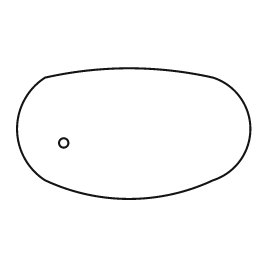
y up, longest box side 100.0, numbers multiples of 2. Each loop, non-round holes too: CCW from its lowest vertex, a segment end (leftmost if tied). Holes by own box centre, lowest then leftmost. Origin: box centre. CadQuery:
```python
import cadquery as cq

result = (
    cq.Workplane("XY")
    .moveTo(-38.0, -20.0)
    .threePointArc((-2.0, -28.0), (34.0, -20.0))
    .threePointArc((50.0, 2.0), (34.0, 24.0))
    .threePointArc((-2.0, 28.0), (-38.0, 24.0))
    .threePointArc((-50.0, 2.0), (-38.0, -20.0))
    .close()
    .moveTo(-30.0, -4.0)
    .circle(2.0)
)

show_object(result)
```